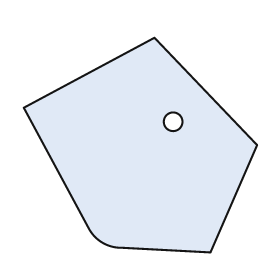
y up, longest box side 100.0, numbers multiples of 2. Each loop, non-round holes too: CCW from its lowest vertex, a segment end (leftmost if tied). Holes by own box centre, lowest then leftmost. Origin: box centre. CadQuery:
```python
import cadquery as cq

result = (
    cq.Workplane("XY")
    .moveTo(30.0, -46.0)
    .lineTo(50.0, 0.0)
    .lineTo(6.0, 46.0)
    .lineTo(-50.0, 16.0)
    .lineTo(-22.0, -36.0)
    .threePointArc((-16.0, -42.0), (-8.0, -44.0))
    .close()
    .moveTo(14.0, 10.0)
    .circle(4.0)
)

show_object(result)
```